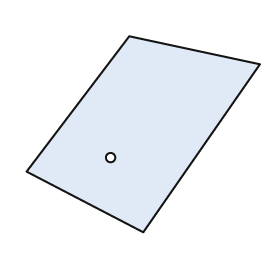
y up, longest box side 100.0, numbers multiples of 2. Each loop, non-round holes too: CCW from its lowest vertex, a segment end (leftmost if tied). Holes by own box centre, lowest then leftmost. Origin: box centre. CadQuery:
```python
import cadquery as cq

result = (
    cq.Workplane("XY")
    .moveTo(0.0, -42.0)
    .lineTo(50.0, 30.0)
    .lineTo(-6.0, 42.0)
    .lineTo(-50.0, -16.0)
    .close()
    .moveTo(-14.0, -10.0)
    .circle(2.0)
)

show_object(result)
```